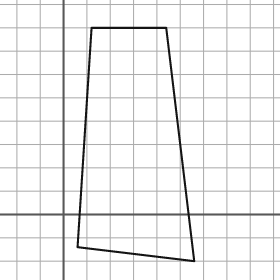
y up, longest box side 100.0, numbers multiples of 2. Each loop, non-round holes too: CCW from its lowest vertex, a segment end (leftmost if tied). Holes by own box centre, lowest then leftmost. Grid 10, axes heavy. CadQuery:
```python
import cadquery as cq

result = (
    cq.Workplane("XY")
    .moveTo(56.0, -20.0)
    .lineTo(44.0, 80.0)
    .lineTo(12.0, 80.0)
    .lineTo(6.0, -14.0)
    .close()
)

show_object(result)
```